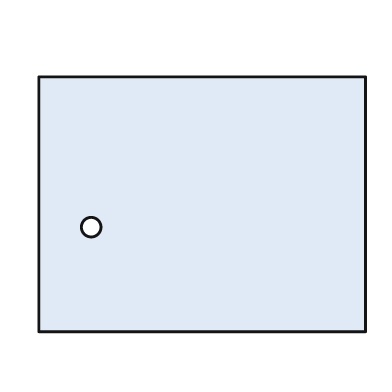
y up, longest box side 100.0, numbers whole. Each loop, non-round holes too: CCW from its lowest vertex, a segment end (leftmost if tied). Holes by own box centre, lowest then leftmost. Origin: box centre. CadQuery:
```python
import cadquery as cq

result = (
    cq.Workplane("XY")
    .moveTo(-50.0, -39.0)
    .lineTo(50.0, -39.0)
    .lineTo(50.0, 39.0)
    .lineTo(-50.0, 39.0)
    .close()
    .moveTo(-34.0, -7.0)
    .circle(3.0)
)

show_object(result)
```